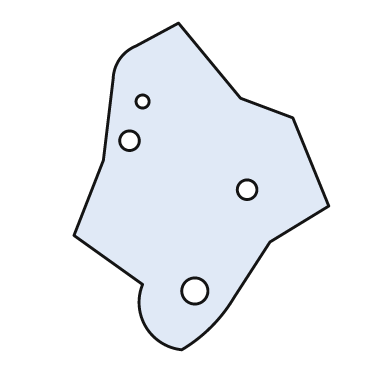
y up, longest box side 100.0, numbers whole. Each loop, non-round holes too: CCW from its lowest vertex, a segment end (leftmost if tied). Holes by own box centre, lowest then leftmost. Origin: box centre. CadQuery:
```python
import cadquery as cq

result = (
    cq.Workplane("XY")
    .moveTo(-6.0, -50.0)
    .threePointArc((3.0, -43.0), (10.0, -34.0))
    .lineTo(21.0, -17.0)
    .lineTo(39.0, -6.0)
    .lineTo(28.0, 21.0)
    .lineTo(12.0, 27.0)
    .lineTo(-7.0, 50.0)
    .lineTo(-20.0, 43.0)
    .threePointArc((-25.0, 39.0), (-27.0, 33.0))
    .lineTo(-30.0, 8.0)
    .lineTo(-39.0, -15.0)
    .lineTo(-18.0, -30.0)
    .threePointArc((-17.0, -43.0), (-6.0, -50.0))
    .close()
    .moveTo(-2.0, -32.0)
    .circle(4.0)
    .moveTo(14.0, -1.0)
    .circle(3.0)
    .moveTo(-22.0, 14.0)
    .circle(3.0)
    .moveTo(-18.0, 26.0)
    .circle(2.0)
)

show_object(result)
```